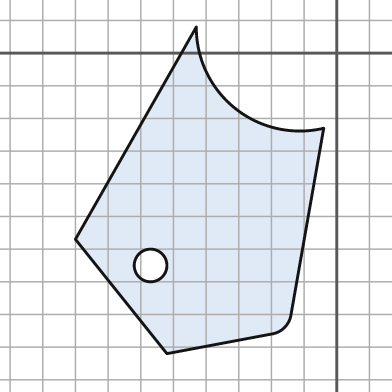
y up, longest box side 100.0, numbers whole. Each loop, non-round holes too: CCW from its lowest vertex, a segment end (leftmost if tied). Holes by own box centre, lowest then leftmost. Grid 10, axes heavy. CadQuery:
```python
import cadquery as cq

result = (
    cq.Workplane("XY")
    .moveTo(-52.0, -92.0)
    .lineTo(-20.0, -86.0)
    .threePointArc((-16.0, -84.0), (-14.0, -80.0))
    .lineTo(-4.0, -23.0)
    .threePointArc((-31.0, -17.0), (-43.0, 8.0))
    .lineTo(-80.0, -57.0)
    .close()
    .moveTo(-57.0, -65.0)
    .circle(5.0)
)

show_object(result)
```